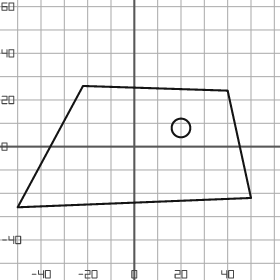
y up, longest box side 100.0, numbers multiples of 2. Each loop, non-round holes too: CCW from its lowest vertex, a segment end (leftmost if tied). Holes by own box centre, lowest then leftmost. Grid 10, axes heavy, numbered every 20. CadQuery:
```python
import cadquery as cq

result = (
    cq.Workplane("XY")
    .moveTo(-50.0, -26.0)
    .lineTo(50.0, -22.0)
    .lineTo(40.0, 24.0)
    .lineTo(-22.0, 26.0)
    .close()
    .moveTo(20.0, 8.0)
    .circle(4.0)
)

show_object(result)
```